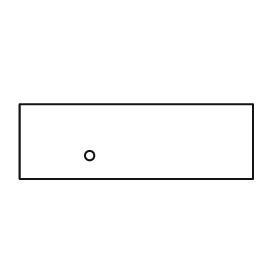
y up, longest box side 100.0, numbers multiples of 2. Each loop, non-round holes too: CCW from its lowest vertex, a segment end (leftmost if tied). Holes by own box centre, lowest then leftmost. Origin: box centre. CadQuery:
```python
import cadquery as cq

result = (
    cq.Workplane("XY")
    .moveTo(-50.0, -16.0)
    .lineTo(50.0, -16.0)
    .lineTo(50.0, 16.0)
    .lineTo(-50.0, 16.0)
    .close()
    .moveTo(-20.0, -6.0)
    .circle(2.0)
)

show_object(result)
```